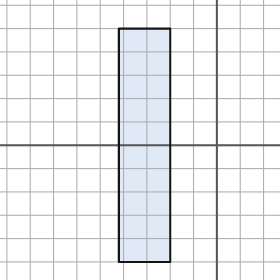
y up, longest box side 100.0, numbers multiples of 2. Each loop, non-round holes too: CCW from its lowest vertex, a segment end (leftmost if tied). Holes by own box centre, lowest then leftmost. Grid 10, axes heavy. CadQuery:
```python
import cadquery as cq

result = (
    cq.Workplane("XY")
    .moveTo(-42.0, -50.0)
    .lineTo(-20.0, -50.0)
    .lineTo(-20.0, 50.0)
    .lineTo(-42.0, 50.0)
    .close()
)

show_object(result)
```